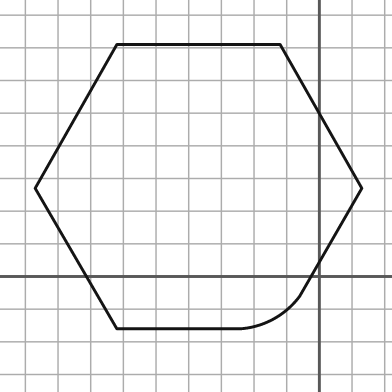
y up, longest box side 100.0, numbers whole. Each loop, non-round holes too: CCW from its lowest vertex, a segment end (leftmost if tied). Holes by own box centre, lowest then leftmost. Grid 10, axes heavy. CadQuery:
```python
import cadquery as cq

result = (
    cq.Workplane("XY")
    .moveTo(-62.0, -16.0)
    .lineTo(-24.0, -16.0)
    .threePointArc((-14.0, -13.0), (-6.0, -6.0))
    .lineTo(13.0, 27.0)
    .lineTo(-12.0, 71.0)
    .lineTo(-62.0, 71.0)
    .lineTo(-87.0, 27.0)
    .close()
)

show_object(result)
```